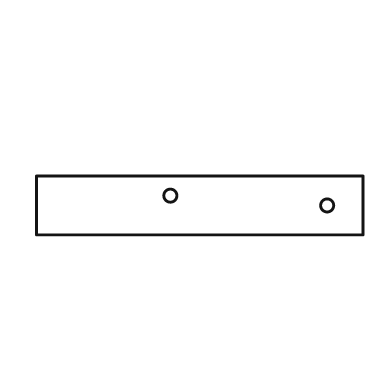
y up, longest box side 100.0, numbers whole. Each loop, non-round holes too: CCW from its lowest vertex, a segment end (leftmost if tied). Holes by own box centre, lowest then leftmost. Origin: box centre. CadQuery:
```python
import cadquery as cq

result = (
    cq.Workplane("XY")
    .moveTo(-50.0, -9.0)
    .lineTo(50.0, -9.0)
    .lineTo(50.0, 9.0)
    .lineTo(-50.0, 9.0)
    .close()
    .moveTo(39.0, 0.0)
    .circle(2.0)
    .moveTo(-9.0, 3.0)
    .circle(2.0)
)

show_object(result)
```